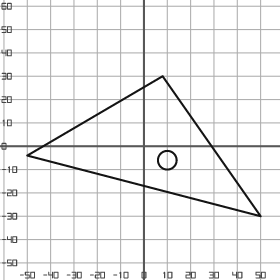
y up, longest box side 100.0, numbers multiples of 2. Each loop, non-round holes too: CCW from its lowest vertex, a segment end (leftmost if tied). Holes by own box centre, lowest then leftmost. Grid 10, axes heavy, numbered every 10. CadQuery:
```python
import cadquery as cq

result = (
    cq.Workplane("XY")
    .moveTo(50.0, -30.0)
    .lineTo(8.0, 30.0)
    .lineTo(-50.0, -4.0)
    .close()
    .moveTo(10.0, -6.0)
    .circle(4.0)
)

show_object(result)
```